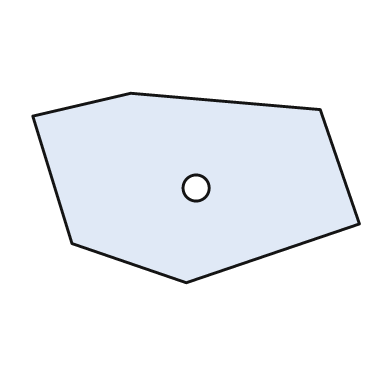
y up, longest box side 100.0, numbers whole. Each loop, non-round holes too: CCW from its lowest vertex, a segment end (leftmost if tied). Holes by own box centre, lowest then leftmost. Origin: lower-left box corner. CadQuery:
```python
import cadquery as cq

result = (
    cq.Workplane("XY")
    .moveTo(47.0, 0.0)
    .lineTo(100.0, 18.0)
    .lineTo(88.0, 53.0)
    .lineTo(30.0, 58.0)
    .lineTo(0.0, 51.0)
    .lineTo(12.0, 12.0)
    .close()
    .moveTo(50.0, 29.0)
    .circle(4.0)
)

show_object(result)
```